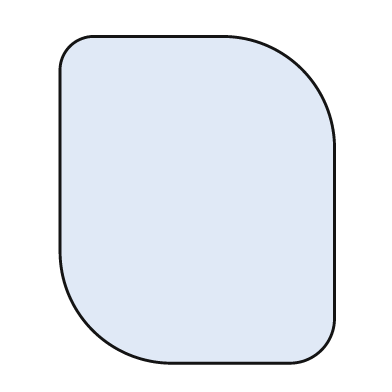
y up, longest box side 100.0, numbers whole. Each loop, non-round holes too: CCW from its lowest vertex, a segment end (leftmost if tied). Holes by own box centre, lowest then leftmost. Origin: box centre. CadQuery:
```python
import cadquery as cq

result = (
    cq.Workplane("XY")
    .moveTo(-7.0, -50.0)
    .lineTo(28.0, -50.0)
    .threePointArc((38.0, -46.0), (42.0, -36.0))
    .lineTo(42.0, 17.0)
    .threePointArc((32.0, 40.0), (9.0, 50.0))
    .lineTo(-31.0, 50.0)
    .threePointArc((-39.0, 47.0), (-42.0, 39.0))
    .lineTo(-42.0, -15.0)
    .threePointArc((-32.0, -40.0), (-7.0, -50.0))
    .close()
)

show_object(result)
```